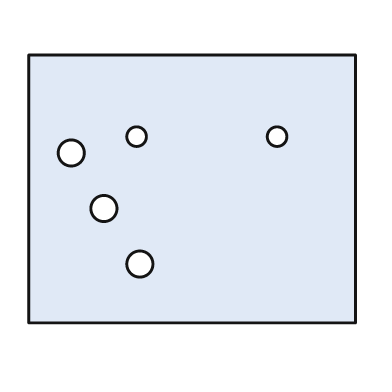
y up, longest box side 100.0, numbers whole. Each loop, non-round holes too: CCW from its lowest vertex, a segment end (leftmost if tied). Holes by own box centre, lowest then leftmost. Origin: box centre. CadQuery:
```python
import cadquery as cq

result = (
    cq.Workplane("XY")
    .moveTo(-50.0, -41.0)
    .lineTo(50.0, -41.0)
    .lineTo(50.0, 41.0)
    .lineTo(-50.0, 41.0)
    .close()
    .moveTo(-16.0, -23.0)
    .circle(4.0)
    .moveTo(-27.0, -6.0)
    .circle(4.0)
    .moveTo(-37.0, 11.0)
    .circle(4.0)
    .moveTo(-17.0, 16.0)
    .circle(3.0)
    .moveTo(26.0, 16.0)
    .circle(3.0)
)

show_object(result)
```